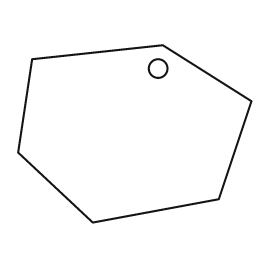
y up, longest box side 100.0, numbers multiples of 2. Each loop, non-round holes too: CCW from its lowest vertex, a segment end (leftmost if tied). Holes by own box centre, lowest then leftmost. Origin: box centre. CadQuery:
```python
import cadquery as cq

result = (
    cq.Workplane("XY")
    .moveTo(-18.0, -38.0)
    .lineTo(36.0, -28.0)
    .lineTo(50.0, 14.0)
    .lineTo(12.0, 38.0)
    .lineTo(-44.0, 32.0)
    .lineTo(-50.0, -8.0)
    .close()
    .moveTo(10.0, 28.0)
    .circle(4.0)
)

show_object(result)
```